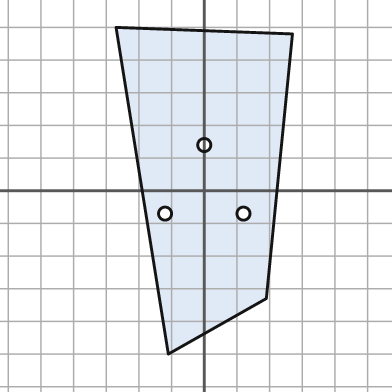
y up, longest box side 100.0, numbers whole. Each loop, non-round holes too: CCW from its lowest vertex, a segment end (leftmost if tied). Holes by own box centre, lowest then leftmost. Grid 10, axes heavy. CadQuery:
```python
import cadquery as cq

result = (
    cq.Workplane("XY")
    .moveTo(-11.0, -50.0)
    .lineTo(19.0, -33.0)
    .lineTo(27.0, 48.0)
    .lineTo(-27.0, 50.0)
    .close()
    .moveTo(-12.0, -7.0)
    .circle(2.0)
    .moveTo(12.0, -7.0)
    .circle(2.0)
    .moveTo(0.0, 14.0)
    .circle(2.0)
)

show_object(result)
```